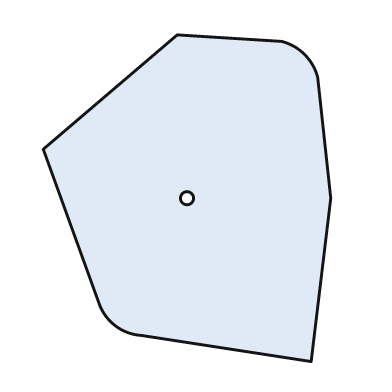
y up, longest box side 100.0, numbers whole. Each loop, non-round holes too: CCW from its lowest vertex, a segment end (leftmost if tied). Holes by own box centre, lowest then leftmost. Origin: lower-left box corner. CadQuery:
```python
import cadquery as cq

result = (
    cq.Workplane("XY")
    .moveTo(82.0, 0.0)
    .lineTo(88.0, 50.0)
    .lineTo(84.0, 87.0)
    .threePointArc((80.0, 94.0), (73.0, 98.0))
    .lineTo(41.0, 100.0)
    .lineTo(0.0, 65.0)
    .lineTo(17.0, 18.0)
    .threePointArc((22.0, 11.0), (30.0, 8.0))
    .close()
    .moveTo(44.0, 50.0)
    .circle(2.0)
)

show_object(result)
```